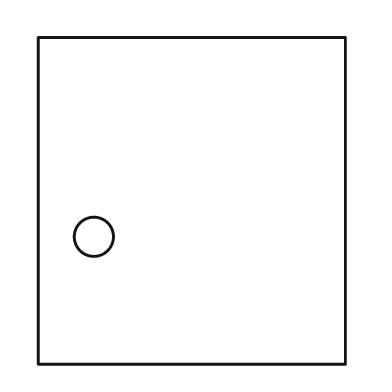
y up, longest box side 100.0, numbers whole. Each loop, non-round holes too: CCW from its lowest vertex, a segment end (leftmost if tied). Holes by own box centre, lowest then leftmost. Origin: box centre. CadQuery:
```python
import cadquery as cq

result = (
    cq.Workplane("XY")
    .moveTo(-47.0, -50.0)
    .lineTo(47.0, -50.0)
    .lineTo(47.0, 50.0)
    .lineTo(-47.0, 50.0)
    .close()
    .moveTo(-30.0, -11.0)
    .circle(6.0)
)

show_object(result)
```